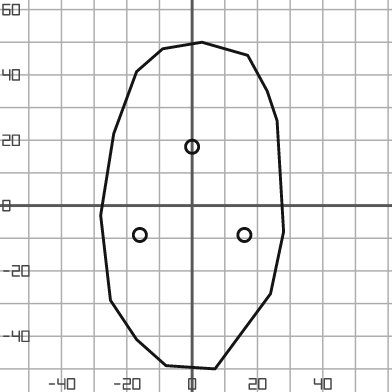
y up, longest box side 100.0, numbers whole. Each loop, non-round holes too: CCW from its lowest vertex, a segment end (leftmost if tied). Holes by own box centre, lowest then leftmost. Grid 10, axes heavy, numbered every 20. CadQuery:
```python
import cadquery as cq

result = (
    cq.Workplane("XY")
    .moveTo(7.0, -50.0)
    .lineTo(24.0, -27.0)
    .lineTo(28.0, -8.0)
    .lineTo(26.0, 26.0)
    .lineTo(23.0, 35.0)
    .lineTo(17.0, 46.0)
    .lineTo(3.0, 50.0)
    .lineTo(-9.0, 48.0)
    .lineTo(-17.0, 41.0)
    .lineTo(-24.0, 22.0)
    .lineTo(-28.0, -3.0)
    .lineTo(-25.0, -29.0)
    .lineTo(-17.0, -41.0)
    .lineTo(-8.0, -49.0)
    .close()
    .moveTo(-16.0, -9.0)
    .circle(2.0)
    .moveTo(16.0, -9.0)
    .circle(2.0)
    .moveTo(0.0, 18.0)
    .circle(2.0)
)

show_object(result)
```